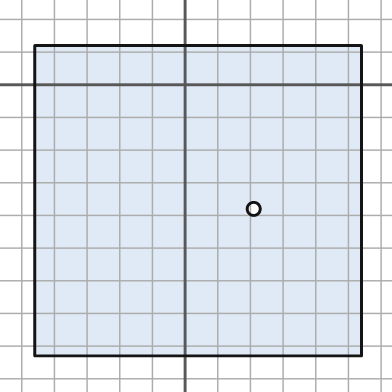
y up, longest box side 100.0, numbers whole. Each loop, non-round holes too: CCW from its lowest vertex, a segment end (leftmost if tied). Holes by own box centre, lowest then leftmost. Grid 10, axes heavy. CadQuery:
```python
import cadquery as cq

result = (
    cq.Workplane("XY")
    .moveTo(-46.0, -83.0)
    .lineTo(54.0, -83.0)
    .lineTo(54.0, 12.0)
    .lineTo(-46.0, 12.0)
    .close()
    .moveTo(21.0, -38.0)
    .circle(2.0)
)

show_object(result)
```